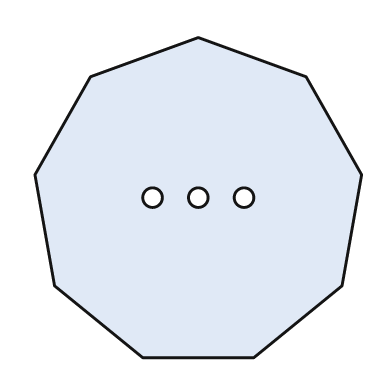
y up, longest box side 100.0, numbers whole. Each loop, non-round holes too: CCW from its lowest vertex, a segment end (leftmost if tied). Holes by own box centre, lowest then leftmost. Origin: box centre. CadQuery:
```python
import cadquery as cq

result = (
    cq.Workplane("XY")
    .moveTo(-17.0, -49.0)
    .lineTo(17.0, -49.0)
    .lineTo(44.0, -27.0)
    .lineTo(50.0, 7.0)
    .lineTo(33.0, 37.0)
    .lineTo(0.0, 49.0)
    .lineTo(-33.0, 37.0)
    .lineTo(-50.0, 7.0)
    .lineTo(-44.0, -27.0)
    .close()
    .moveTo(-14.0, 0.0)
    .circle(3.0)
    .moveTo(0.0, 0.0)
    .circle(3.0)
    .moveTo(14.0, 0.0)
    .circle(3.0)
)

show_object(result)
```